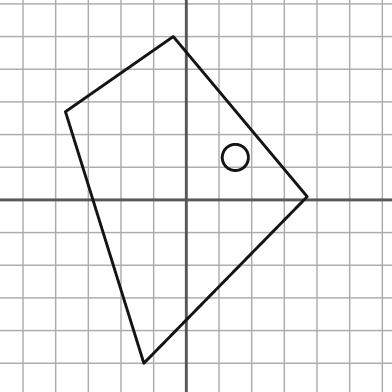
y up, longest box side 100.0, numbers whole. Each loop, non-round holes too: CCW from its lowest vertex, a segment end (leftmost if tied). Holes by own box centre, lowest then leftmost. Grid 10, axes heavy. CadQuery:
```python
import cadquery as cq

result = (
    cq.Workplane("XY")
    .moveTo(-13.0, -50.0)
    .lineTo(37.0, 1.0)
    .lineTo(-4.0, 50.0)
    .lineTo(-37.0, 27.0)
    .close()
    .moveTo(15.0, 13.0)
    .circle(4.0)
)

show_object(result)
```